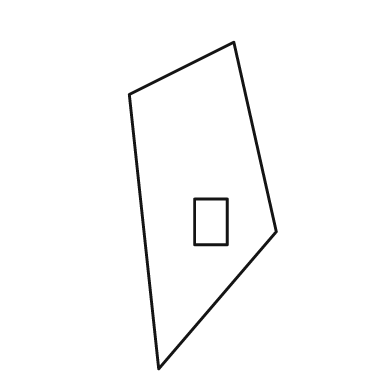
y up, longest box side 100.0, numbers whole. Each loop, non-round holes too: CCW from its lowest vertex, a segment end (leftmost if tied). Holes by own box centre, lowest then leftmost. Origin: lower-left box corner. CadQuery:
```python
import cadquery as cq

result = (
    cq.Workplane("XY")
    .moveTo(9.0, 0.0)
    .lineTo(45.0, 42.0)
    .lineTo(32.0, 100.0)
    .lineTo(0.0, 84.0)
    .close()
    .moveTo(20.0, 38.0)
    .lineTo(30.0, 38.0)
    .lineTo(30.0, 52.0)
    .lineTo(20.0, 52.0)
    .close()
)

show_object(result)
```